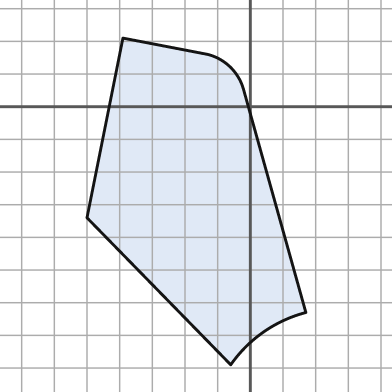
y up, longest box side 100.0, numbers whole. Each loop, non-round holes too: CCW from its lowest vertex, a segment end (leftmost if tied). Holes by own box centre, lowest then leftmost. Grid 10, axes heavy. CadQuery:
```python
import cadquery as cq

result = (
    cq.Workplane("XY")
    .moveTo(-6.0, -79.0)
    .threePointArc((4.0, -69.0), (17.0, -63.0))
    .lineTo(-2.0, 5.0)
    .threePointArc((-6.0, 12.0), (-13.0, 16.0))
    .lineTo(-39.0, 21.0)
    .lineTo(-50.0, -34.0)
    .close()
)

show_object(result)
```